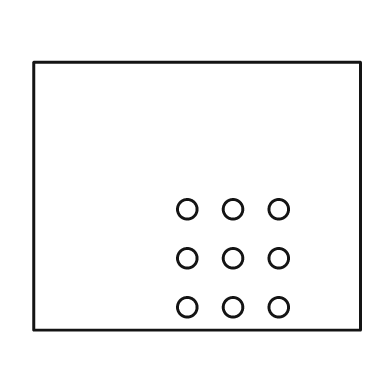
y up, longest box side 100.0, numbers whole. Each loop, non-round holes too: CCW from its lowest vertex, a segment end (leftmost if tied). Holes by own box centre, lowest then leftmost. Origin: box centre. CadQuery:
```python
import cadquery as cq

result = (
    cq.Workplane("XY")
    .moveTo(-50.0, -41.0)
    .lineTo(50.0, -41.0)
    .lineTo(50.0, 41.0)
    .lineTo(-50.0, 41.0)
    .close()
    .moveTo(-3.0, -34.0)
    .circle(3.0)
    .moveTo(11.0, -34.0)
    .circle(3.0)
    .moveTo(25.0, -34.0)
    .circle(3.0)
    .moveTo(-3.0, -19.0)
    .circle(3.0)
    .moveTo(11.0, -19.0)
    .circle(3.0)
    .moveTo(25.0, -19.0)
    .circle(3.0)
    .moveTo(-3.0, -4.0)
    .circle(3.0)
    .moveTo(11.0, -4.0)
    .circle(3.0)
    .moveTo(25.0, -4.0)
    .circle(3.0)
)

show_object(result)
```